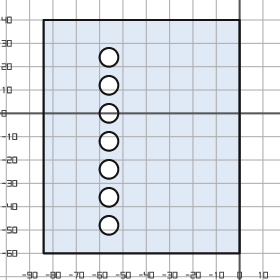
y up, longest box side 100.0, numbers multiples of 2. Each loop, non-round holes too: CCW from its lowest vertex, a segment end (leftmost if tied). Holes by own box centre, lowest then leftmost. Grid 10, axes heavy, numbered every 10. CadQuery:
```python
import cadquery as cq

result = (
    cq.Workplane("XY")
    .moveTo(-84.0, -60.0)
    .lineTo(0.0, -60.0)
    .lineTo(0.0, 40.0)
    .lineTo(-84.0, 40.0)
    .close()
    .moveTo(-56.0, -48.0)
    .circle(4.0)
    .moveTo(-56.0, -36.0)
    .circle(4.0)
    .moveTo(-56.0, -24.0)
    .circle(4.0)
    .moveTo(-56.0, -12.0)
    .circle(4.0)
    .moveTo(-56.0, 0.0)
    .circle(4.0)
    .moveTo(-56.0, 12.0)
    .circle(4.0)
    .moveTo(-56.0, 24.0)
    .circle(4.0)
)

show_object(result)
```